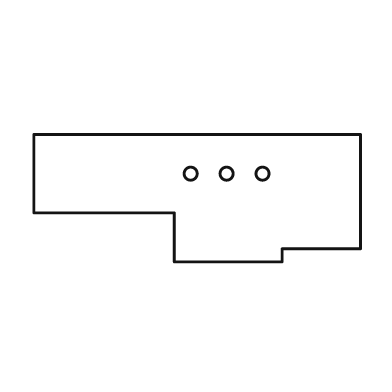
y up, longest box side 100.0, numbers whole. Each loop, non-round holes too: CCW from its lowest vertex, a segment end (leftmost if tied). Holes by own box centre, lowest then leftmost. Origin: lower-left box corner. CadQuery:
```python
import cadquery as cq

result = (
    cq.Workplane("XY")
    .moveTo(43.0, 0.0)
    .lineTo(76.0, 0.0)
    .lineTo(76.0, 4.0)
    .lineTo(100.0, 4.0)
    .lineTo(100.0, 39.0)
    .lineTo(0.0, 39.0)
    .lineTo(0.0, 15.0)
    .lineTo(43.0, 15.0)
    .close()
    .moveTo(48.0, 27.0)
    .circle(2.0)
    .moveTo(59.0, 27.0)
    .circle(2.0)
    .moveTo(70.0, 27.0)
    .circle(2.0)
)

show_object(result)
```